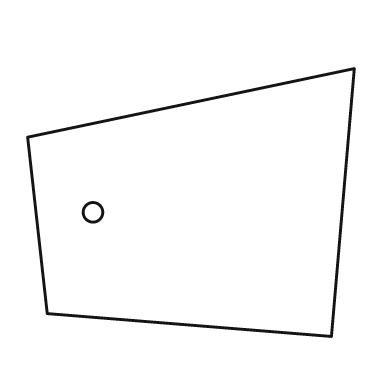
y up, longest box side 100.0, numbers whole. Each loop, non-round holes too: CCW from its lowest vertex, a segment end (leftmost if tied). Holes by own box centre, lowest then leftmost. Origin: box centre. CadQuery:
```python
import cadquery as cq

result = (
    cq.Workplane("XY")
    .moveTo(43.0, -41.0)
    .lineTo(50.0, 41.0)
    .lineTo(-50.0, 20.0)
    .lineTo(-44.0, -34.0)
    .close()
    .moveTo(-30.0, -3.0)
    .circle(3.0)
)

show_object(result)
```